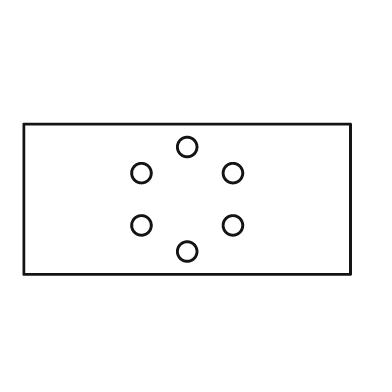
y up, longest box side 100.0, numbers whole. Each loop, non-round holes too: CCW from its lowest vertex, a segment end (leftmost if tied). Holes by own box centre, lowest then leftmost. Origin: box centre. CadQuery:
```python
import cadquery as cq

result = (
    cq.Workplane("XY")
    .moveTo(-50.0, -23.0)
    .lineTo(50.0, -23.0)
    .lineTo(50.0, 23.0)
    .lineTo(-50.0, 23.0)
    .close()
    .moveTo(0.0, -16.0)
    .circle(3.0)
    .moveTo(-14.0, -8.0)
    .circle(3.0)
    .moveTo(14.0, -8.0)
    .circle(3.0)
    .moveTo(-14.0, 8.0)
    .circle(3.0)
    .moveTo(14.0, 8.0)
    .circle(3.0)
    .moveTo(0.0, 16.0)
    .circle(3.0)
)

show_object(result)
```